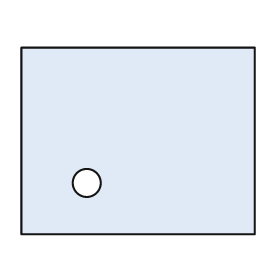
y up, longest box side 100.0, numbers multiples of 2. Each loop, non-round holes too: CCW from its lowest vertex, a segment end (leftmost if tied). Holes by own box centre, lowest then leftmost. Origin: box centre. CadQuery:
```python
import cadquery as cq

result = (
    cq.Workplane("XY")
    .moveTo(-50.0, -40.0)
    .lineTo(50.0, -40.0)
    .lineTo(50.0, 40.0)
    .lineTo(-50.0, 40.0)
    .close()
    .moveTo(-22.0, -18.0)
    .circle(6.0)
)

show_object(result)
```